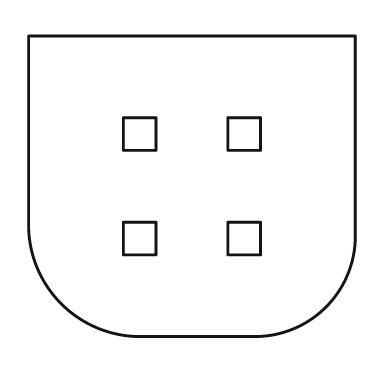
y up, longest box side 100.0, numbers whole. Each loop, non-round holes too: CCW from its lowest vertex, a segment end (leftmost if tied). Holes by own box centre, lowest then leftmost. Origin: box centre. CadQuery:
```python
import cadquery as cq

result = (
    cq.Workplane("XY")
    .moveTo(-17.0, -46.0)
    .lineTo(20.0, -46.0)
    .threePointArc((41.0, -37.0), (50.0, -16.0))
    .lineTo(50.0, 46.0)
    .lineTo(-50.0, 46.0)
    .lineTo(-50.0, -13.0)
    .threePointArc((-40.0, -36.0), (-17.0, -46.0))
    .close()
    .moveTo(-21.0, -21.0)
    .lineTo(-11.0, -21.0)
    .lineTo(-11.0, -11.0)
    .lineTo(-21.0, -11.0)
    .close()
    .moveTo(11.0, -21.0)
    .lineTo(21.0, -21.0)
    .lineTo(21.0, -11.0)
    .lineTo(11.0, -11.0)
    .close()
    .moveTo(-21.0, 11.0)
    .lineTo(-11.0, 11.0)
    .lineTo(-11.0, 21.0)
    .lineTo(-21.0, 21.0)
    .close()
    .moveTo(11.0, 11.0)
    .lineTo(21.0, 11.0)
    .lineTo(21.0, 21.0)
    .lineTo(11.0, 21.0)
    .close()
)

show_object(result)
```